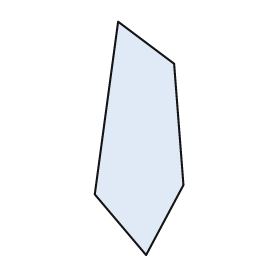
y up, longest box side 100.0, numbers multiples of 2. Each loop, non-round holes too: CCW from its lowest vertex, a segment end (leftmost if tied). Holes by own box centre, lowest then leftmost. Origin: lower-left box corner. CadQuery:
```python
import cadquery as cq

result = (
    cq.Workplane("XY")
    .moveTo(22.0, 0.0)
    .lineTo(38.0, 30.0)
    .lineTo(34.0, 82.0)
    .lineTo(10.0, 100.0)
    .lineTo(0.0, 26.0)
    .close()
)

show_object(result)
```